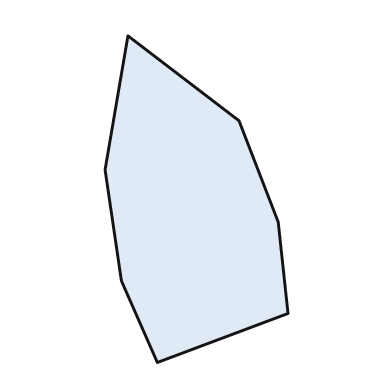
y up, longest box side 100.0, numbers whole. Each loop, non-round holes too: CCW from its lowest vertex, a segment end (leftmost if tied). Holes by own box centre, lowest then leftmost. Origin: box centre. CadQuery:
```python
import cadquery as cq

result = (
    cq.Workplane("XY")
    .moveTo(-12.0, -50.0)
    .lineTo(28.0, -35.0)
    .lineTo(25.0, -7.0)
    .lineTo(13.0, 24.0)
    .lineTo(-21.0, 50.0)
    .lineTo(-28.0, 9.0)
    .lineTo(-23.0, -25.0)
    .close()
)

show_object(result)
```